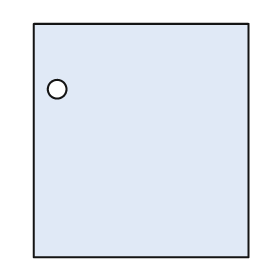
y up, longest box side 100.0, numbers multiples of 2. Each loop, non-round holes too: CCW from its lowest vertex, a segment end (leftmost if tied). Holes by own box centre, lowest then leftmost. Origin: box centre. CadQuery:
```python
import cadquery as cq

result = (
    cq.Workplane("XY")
    .moveTo(-46.0, -50.0)
    .lineTo(46.0, -50.0)
    .lineTo(46.0, 50.0)
    .lineTo(-46.0, 50.0)
    .close()
    .moveTo(-36.0, 22.0)
    .circle(4.0)
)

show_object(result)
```